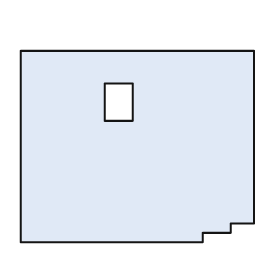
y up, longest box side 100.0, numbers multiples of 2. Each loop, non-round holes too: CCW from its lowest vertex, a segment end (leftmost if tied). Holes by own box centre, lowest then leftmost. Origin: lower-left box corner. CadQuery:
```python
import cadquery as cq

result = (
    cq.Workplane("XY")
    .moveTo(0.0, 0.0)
    .lineTo(78.0, 0.0)
    .lineTo(78.0, 4.0)
    .lineTo(90.0, 4.0)
    .lineTo(90.0, 8.0)
    .lineTo(100.0, 8.0)
    .lineTo(100.0, 82.0)
    .lineTo(0.0, 82.0)
    .close()
    .moveTo(36.0, 52.0)
    .lineTo(48.0, 52.0)
    .lineTo(48.0, 68.0)
    .lineTo(36.0, 68.0)
    .close()
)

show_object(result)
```